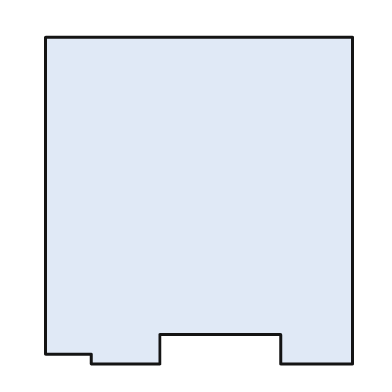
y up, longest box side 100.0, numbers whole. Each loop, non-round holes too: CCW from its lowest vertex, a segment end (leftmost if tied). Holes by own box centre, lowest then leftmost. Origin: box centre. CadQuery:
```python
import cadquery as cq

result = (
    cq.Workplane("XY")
    .moveTo(-33.0, -50.0)
    .lineTo(-12.0, -50.0)
    .lineTo(-12.0, -41.0)
    .lineTo(25.0, -41.0)
    .lineTo(25.0, -50.0)
    .lineTo(47.0, -50.0)
    .lineTo(47.0, 50.0)
    .lineTo(-47.0, 50.0)
    .lineTo(-47.0, -47.0)
    .lineTo(-33.0, -47.0)
    .close()
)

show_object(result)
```